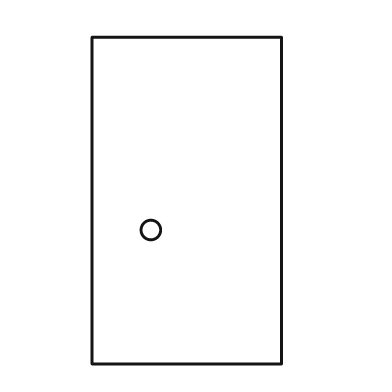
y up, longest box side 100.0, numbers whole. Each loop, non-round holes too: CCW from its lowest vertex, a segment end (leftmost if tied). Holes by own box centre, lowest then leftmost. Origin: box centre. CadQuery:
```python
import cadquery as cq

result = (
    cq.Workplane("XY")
    .moveTo(-29.0, -50.0)
    .lineTo(29.0, -50.0)
    .lineTo(29.0, 50.0)
    .lineTo(-29.0, 50.0)
    .close()
    .moveTo(-11.0, -9.0)
    .circle(3.0)
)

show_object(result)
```